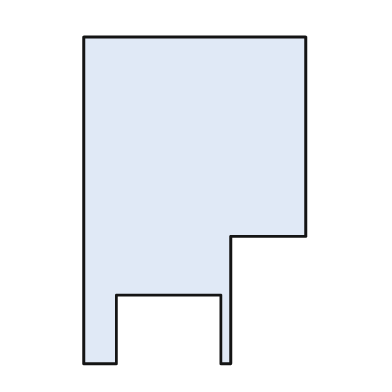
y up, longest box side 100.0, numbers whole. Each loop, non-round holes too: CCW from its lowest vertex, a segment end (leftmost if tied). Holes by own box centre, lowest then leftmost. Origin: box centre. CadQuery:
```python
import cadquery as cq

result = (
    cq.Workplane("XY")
    .moveTo(-34.0, -50.0)
    .lineTo(-24.0, -50.0)
    .lineTo(-24.0, -29.0)
    .lineTo(8.0, -29.0)
    .lineTo(8.0, -50.0)
    .lineTo(11.0, -50.0)
    .lineTo(11.0, -11.0)
    .lineTo(34.0, -11.0)
    .lineTo(34.0, 50.0)
    .lineTo(-34.0, 50.0)
    .close()
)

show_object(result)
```